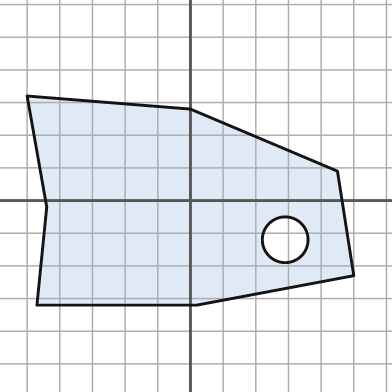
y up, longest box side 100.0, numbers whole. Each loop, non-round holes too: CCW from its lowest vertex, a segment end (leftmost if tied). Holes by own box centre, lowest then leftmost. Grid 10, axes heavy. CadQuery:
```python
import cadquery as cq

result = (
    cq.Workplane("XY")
    .moveTo(-47.0, -32.0)
    .lineTo(2.0, -32.0)
    .lineTo(50.0, -23.0)
    .lineTo(45.0, 9.0)
    .lineTo(0.0, 28.0)
    .lineTo(-50.0, 32.0)
    .lineTo(-44.0, -2.0)
    .close()
    .moveTo(29.0, -12.0)
    .circle(7.0)
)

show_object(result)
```